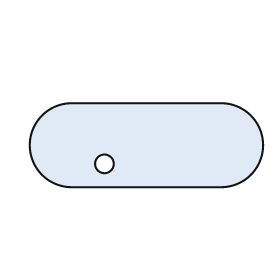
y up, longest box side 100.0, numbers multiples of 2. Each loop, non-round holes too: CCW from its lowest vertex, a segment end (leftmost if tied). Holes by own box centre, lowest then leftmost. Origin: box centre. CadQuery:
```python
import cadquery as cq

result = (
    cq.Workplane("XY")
    .moveTo(-32.0, -18.0)
    .lineTo(32.0, -18.0)
    .threePointArc((50.0, 0.0), (32.0, 18.0))
    .lineTo(-32.0, 18.0)
    .threePointArc((-50.0, 0.0), (-32.0, -18.0))
    .close()
    .moveTo(-18.0, -8.0)
    .circle(4.0)
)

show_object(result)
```